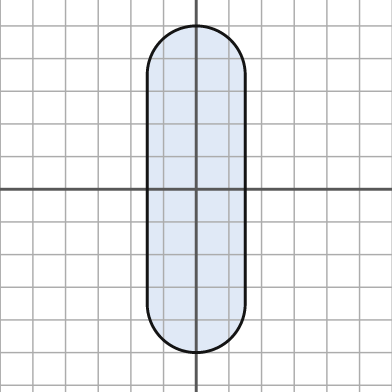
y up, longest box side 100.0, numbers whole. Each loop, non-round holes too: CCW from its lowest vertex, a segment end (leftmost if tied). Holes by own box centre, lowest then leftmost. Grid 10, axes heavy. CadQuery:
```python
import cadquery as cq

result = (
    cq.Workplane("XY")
    .moveTo(-15.0, -35.0)
    .threePointArc((0.0, -50.0), (15.0, -35.0))
    .lineTo(15.0, 35.0)
    .threePointArc((0.0, 50.0), (-15.0, 35.0))
    .close()
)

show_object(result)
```